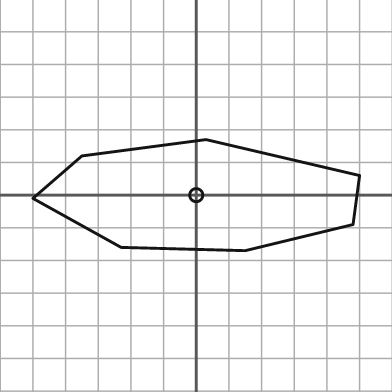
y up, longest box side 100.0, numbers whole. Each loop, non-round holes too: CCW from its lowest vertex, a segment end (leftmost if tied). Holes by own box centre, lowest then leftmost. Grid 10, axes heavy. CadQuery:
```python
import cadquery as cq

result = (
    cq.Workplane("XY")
    .moveTo(15.0, -17.0)
    .lineTo(48.0, -9.0)
    .lineTo(50.0, 6.0)
    .lineTo(3.0, 17.0)
    .lineTo(-35.0, 12.0)
    .lineTo(-50.0, -1.0)
    .lineTo(-23.0, -16.0)
    .close()
    .moveTo(0.0, 0.0)
    .circle(2.0)
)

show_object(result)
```